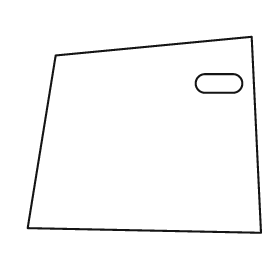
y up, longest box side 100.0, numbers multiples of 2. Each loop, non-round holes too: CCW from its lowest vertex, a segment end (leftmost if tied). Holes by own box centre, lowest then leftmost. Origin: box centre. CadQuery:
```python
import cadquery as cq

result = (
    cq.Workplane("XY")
    .moveTo(50.0, -42.0)
    .lineTo(46.0, 42.0)
    .lineTo(-38.0, 34.0)
    .lineTo(-50.0, -40.0)
    .close()
    .moveTo(26.0, 18.0)
    .lineTo(38.0, 18.0)
    .threePointArc((42.0, 22.0), (38.0, 26.0))
    .lineTo(26.0, 26.0)
    .threePointArc((22.0, 22.0), (26.0, 18.0))
    .close()
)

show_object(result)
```